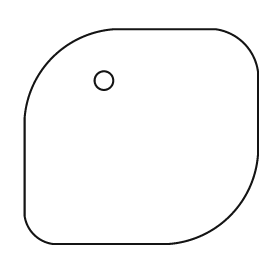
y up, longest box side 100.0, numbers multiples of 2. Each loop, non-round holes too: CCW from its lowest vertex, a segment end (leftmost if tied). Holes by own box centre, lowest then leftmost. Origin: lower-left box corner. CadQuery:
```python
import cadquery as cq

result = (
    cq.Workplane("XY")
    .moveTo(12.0, 0.0)
    .lineTo(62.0, 0.0)
    .threePointArc((88.0, 12.0), (100.0, 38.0))
    .lineTo(100.0, 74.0)
    .threePointArc((94.0, 86.0), (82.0, 92.0))
    .lineTo(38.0, 92.0)
    .threePointArc((12.0, 80.0), (0.0, 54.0))
    .lineTo(0.0, 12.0)
    .threePointArc((4.0, 4.0), (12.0, 0.0))
    .close()
    .moveTo(34.0, 70.0)
    .circle(4.0)
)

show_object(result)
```